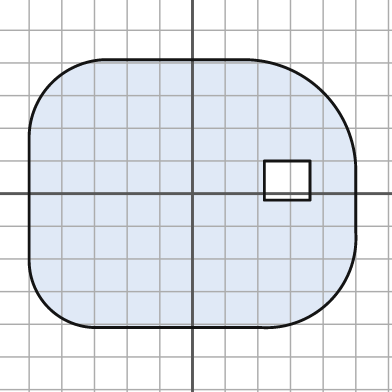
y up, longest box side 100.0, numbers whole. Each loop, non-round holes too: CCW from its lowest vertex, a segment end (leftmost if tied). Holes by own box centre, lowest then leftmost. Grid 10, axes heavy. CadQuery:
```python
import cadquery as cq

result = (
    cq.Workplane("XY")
    .moveTo(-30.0, -41.0)
    .lineTo(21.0, -41.0)
    .threePointArc((42.0, -33.0), (50.0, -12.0))
    .lineTo(50.0, 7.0)
    .threePointArc((40.0, 31.0), (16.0, 41.0))
    .lineTo(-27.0, 41.0)
    .threePointArc((-43.0, 34.0), (-50.0, 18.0))
    .lineTo(-50.0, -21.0)
    .threePointArc((-44.0, -35.0), (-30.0, -41.0))
    .close()
    .moveTo(22.0, -2.0)
    .lineTo(36.0, -2.0)
    .lineTo(36.0, 10.0)
    .lineTo(22.0, 10.0)
    .close()
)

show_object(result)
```